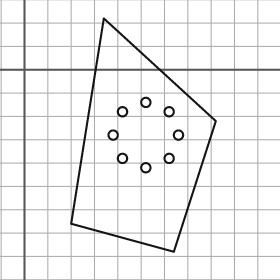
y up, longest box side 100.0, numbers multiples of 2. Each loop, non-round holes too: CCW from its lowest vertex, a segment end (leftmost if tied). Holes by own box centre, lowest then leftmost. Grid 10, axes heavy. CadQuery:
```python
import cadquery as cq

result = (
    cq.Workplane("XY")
    .moveTo(64.0, -78.0)
    .lineTo(82.0, -22.0)
    .lineTo(34.0, 22.0)
    .lineTo(20.0, -66.0)
    .close()
    .moveTo(52.0, -42.0)
    .circle(2.0)
    .moveTo(42.0, -38.0)
    .circle(2.0)
    .moveTo(62.0, -38.0)
    .circle(2.0)
    .moveTo(38.0, -28.0)
    .circle(2.0)
    .moveTo(66.0, -28.0)
    .circle(2.0)
    .moveTo(42.0, -18.0)
    .circle(2.0)
    .moveTo(62.0, -18.0)
    .circle(2.0)
    .moveTo(52.0, -14.0)
    .circle(2.0)
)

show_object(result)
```